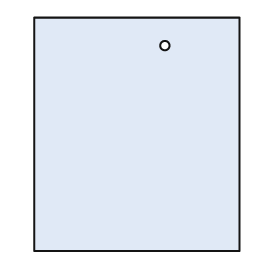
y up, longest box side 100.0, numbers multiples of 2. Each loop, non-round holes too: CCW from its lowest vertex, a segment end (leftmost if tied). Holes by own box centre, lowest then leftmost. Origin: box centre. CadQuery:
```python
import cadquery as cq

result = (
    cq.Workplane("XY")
    .moveTo(-44.0, -50.0)
    .lineTo(44.0, -50.0)
    .lineTo(44.0, 50.0)
    .lineTo(-44.0, 50.0)
    .close()
    .moveTo(12.0, 38.0)
    .circle(2.0)
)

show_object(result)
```